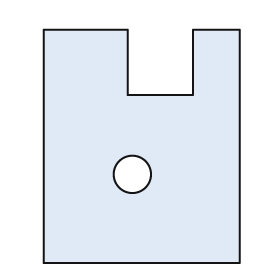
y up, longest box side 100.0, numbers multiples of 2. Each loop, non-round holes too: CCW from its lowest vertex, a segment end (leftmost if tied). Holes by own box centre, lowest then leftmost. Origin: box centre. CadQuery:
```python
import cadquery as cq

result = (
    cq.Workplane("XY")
    .moveTo(-42.0, -50.0)
    .lineTo(42.0, -50.0)
    .lineTo(42.0, 50.0)
    .lineTo(22.0, 50.0)
    .lineTo(22.0, 22.0)
    .lineTo(-6.0, 22.0)
    .lineTo(-6.0, 50.0)
    .lineTo(-42.0, 50.0)
    .close()
    .moveTo(-4.0, -12.0)
    .circle(8.0)
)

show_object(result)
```